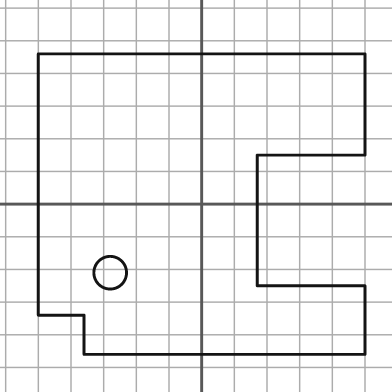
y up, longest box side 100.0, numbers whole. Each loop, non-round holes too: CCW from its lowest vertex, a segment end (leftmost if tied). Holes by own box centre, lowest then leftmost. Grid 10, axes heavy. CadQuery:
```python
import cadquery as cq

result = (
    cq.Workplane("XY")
    .moveTo(-36.0, -46.0)
    .lineTo(50.0, -46.0)
    .lineTo(50.0, -25.0)
    .lineTo(17.0, -25.0)
    .lineTo(17.0, 15.0)
    .lineTo(50.0, 15.0)
    .lineTo(50.0, 46.0)
    .lineTo(-50.0, 46.0)
    .lineTo(-50.0, -34.0)
    .lineTo(-36.0, -34.0)
    .close()
    .moveTo(-28.0, -21.0)
    .circle(5.0)
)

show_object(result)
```